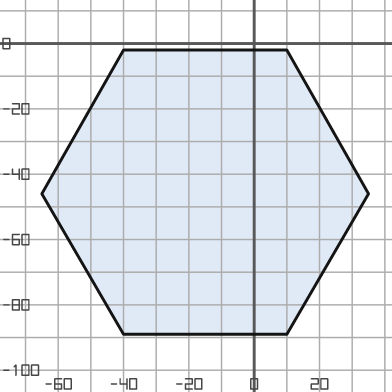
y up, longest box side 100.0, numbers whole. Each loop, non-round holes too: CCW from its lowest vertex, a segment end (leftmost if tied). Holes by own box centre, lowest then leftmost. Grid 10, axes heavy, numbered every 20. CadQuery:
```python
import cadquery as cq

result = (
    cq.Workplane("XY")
    .moveTo(-40.0, -89.0)
    .lineTo(10.0, -89.0)
    .lineTo(35.0, -46.0)
    .lineTo(10.0, -2.0)
    .lineTo(-40.0, -2.0)
    .lineTo(-65.0, -46.0)
    .close()
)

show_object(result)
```